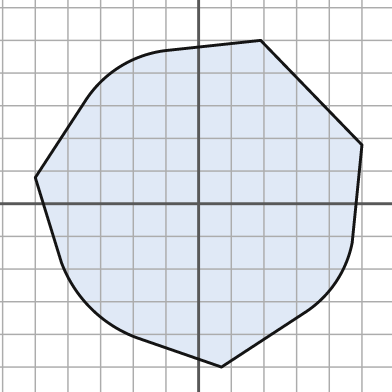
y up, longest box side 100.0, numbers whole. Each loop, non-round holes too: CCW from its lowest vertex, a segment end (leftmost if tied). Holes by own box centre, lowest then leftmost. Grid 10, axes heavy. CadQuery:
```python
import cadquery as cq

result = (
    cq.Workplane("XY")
    .moveTo(7.0, -50.0)
    .lineTo(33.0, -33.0)
    .threePointArc((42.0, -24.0), (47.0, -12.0))
    .lineTo(50.0, 18.0)
    .lineTo(19.0, 50.0)
    .lineTo(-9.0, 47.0)
    .threePointArc((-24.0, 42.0), (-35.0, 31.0))
    .lineTo(-50.0, 8.0)
    .lineTo(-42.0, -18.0)
    .threePointArc((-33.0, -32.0), (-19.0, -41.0))
    .close()
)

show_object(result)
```